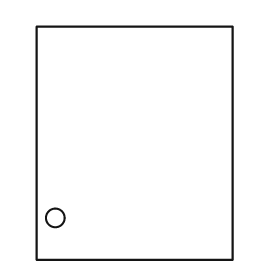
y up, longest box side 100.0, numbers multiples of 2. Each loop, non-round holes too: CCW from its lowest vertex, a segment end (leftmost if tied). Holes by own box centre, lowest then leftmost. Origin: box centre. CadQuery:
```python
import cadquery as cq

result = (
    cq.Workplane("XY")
    .moveTo(-42.0, -50.0)
    .lineTo(42.0, -50.0)
    .lineTo(42.0, 50.0)
    .lineTo(-42.0, 50.0)
    .close()
    .moveTo(-34.0, -32.0)
    .circle(4.0)
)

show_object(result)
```